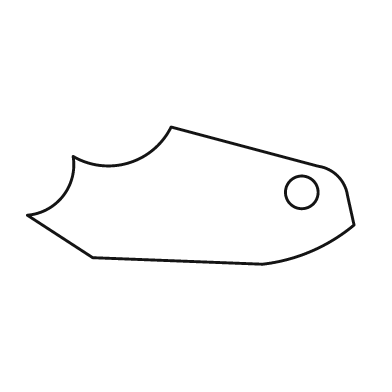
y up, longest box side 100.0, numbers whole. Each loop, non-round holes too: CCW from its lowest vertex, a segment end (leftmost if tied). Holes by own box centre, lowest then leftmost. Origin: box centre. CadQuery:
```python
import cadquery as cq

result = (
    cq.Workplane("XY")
    .moveTo(22.0, -21.0)
    .threePointArc((37.0, -17.0), (50.0, -9.0))
    .lineTo(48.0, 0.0)
    .threePointArc((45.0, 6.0), (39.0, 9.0))
    .lineTo(-6.0, 21.0)
    .threePointArc((-19.0, 10.0), (-36.0, 12.0))
    .threePointArc((-39.0, 0.0), (-50.0, -6.0))
    .lineTo(-30.0, -19.0)
    .close()
    .moveTo(34.0, 1.0)
    .circle(5.0)
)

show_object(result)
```